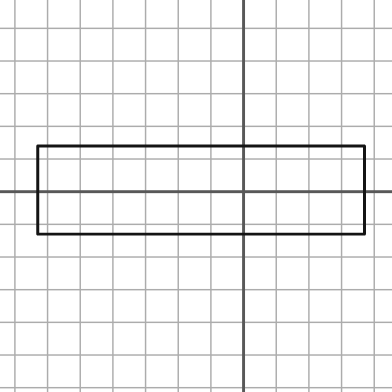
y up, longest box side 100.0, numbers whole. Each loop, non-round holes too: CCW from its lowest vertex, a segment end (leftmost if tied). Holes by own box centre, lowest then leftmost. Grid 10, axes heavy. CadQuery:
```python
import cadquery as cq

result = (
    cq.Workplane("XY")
    .moveTo(-63.0, -13.0)
    .lineTo(37.0, -13.0)
    .lineTo(37.0, 14.0)
    .lineTo(-63.0, 14.0)
    .close()
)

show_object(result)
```